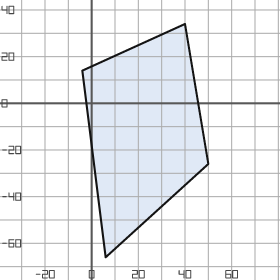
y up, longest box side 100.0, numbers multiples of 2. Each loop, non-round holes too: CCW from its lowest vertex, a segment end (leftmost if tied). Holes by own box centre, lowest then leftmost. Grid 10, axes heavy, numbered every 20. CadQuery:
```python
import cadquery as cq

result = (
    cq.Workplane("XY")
    .moveTo(6.0, -66.0)
    .lineTo(50.0, -26.0)
    .lineTo(40.0, 34.0)
    .lineTo(-4.0, 14.0)
    .close()
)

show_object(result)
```